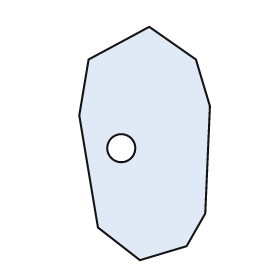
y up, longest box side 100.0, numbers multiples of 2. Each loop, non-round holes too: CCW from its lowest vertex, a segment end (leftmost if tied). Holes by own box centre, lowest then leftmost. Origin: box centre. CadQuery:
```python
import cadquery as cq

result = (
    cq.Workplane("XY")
    .moveTo(-2.0, -50.0)
    .lineTo(18.0, -44.0)
    .lineTo(26.0, -30.0)
    .lineTo(28.0, 16.0)
    .lineTo(22.0, 36.0)
    .lineTo(2.0, 50.0)
    .lineTo(-24.0, 36.0)
    .lineTo(-28.0, 12.0)
    .lineTo(-20.0, -36.0)
    .close()
    .moveTo(-10.0, -2.0)
    .circle(6.0)
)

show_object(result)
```